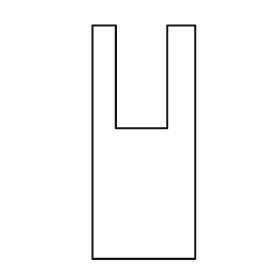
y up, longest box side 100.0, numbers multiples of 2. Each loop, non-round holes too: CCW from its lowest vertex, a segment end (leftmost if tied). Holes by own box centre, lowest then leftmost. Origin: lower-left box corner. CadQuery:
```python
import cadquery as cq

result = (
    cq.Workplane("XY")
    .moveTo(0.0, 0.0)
    .lineTo(44.0, 0.0)
    .lineTo(44.0, 100.0)
    .lineTo(32.0, 100.0)
    .lineTo(32.0, 56.0)
    .lineTo(10.0, 56.0)
    .lineTo(10.0, 100.0)
    .lineTo(0.0, 100.0)
    .close()
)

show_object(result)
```